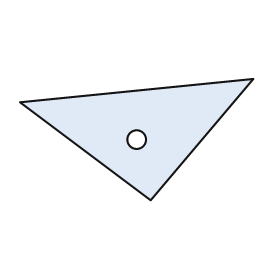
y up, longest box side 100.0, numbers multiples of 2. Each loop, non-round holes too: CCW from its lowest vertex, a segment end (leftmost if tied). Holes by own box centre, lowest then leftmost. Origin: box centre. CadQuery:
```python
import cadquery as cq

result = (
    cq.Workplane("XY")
    .moveTo(6.0, -26.0)
    .lineTo(50.0, 26.0)
    .lineTo(-50.0, 16.0)
    .close()
    .moveTo(0.0, 0.0)
    .circle(4.0)
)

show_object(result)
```